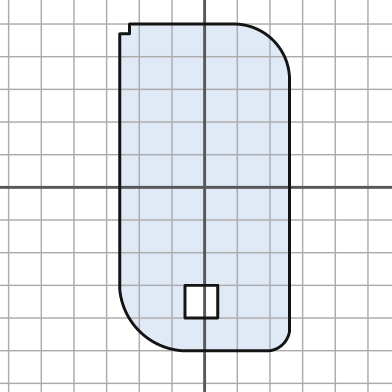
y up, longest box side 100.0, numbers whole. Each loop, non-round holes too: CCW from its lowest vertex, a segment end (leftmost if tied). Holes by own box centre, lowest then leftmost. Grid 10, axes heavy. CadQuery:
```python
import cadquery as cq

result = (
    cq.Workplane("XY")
    .moveTo(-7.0, -50.0)
    .lineTo(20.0, -50.0)
    .threePointArc((24.0, -48.0), (26.0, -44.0))
    .lineTo(26.0, 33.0)
    .threePointArc((21.0, 45.0), (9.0, 50.0))
    .lineTo(-23.0, 50.0)
    .lineTo(-23.0, 47.0)
    .lineTo(-26.0, 47.0)
    .lineTo(-26.0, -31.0)
    .threePointArc((-20.0, -44.0), (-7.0, -50.0))
    .close()
    .moveTo(-6.0, -40.0)
    .lineTo(4.0, -40.0)
    .lineTo(4.0, -30.0)
    .lineTo(-6.0, -30.0)
    .close()
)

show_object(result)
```